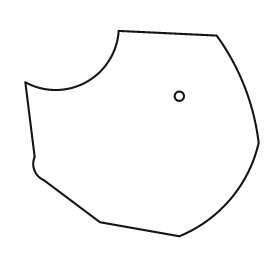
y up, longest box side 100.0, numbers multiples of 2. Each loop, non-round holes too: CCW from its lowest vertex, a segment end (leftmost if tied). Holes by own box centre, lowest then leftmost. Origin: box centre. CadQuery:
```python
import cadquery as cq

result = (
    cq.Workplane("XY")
    .moveTo(16.0, -44.0)
    .threePointArc((38.0, -28.0), (50.0, -4.0))
    .threePointArc((44.0, 20.0), (32.0, 42.0))
    .lineTo(-10.0, 44.0)
    .threePointArc((-24.0, 22.0), (-50.0, 22.0))
    .lineTo(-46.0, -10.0)
    .threePointArc((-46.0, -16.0), (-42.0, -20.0))
    .lineTo(-18.0, -38.0)
    .close()
    .moveTo(16.0, 16.0)
    .circle(2.0)
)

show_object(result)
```